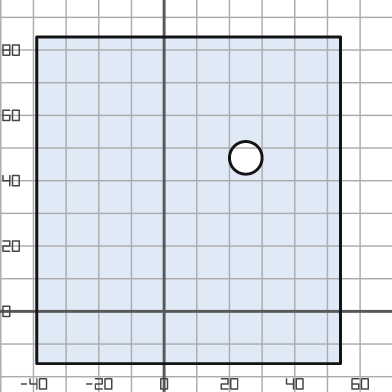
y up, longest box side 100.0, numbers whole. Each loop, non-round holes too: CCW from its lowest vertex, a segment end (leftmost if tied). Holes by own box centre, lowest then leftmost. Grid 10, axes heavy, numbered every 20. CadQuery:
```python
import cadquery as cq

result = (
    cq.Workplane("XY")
    .moveTo(-39.0, -16.0)
    .lineTo(54.0, -16.0)
    .lineTo(54.0, 84.0)
    .lineTo(-39.0, 84.0)
    .close()
    .moveTo(25.0, 47.0)
    .circle(5.0)
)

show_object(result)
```